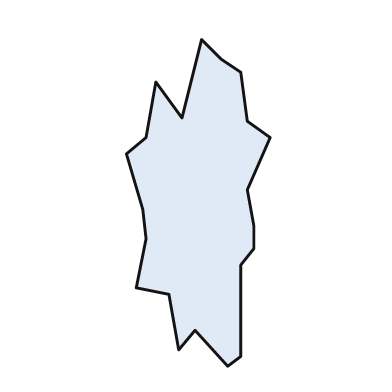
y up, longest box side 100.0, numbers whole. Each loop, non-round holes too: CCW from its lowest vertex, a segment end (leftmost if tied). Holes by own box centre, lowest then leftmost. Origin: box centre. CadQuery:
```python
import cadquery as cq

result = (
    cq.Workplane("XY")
    .moveTo(9.0, -50.0)
    .lineTo(13.0, -47.0)
    .lineTo(13.0, -19.0)
    .lineTo(17.0, -14.0)
    .lineTo(17.0, -7.0)
    .lineTo(15.0, 4.0)
    .lineTo(22.0, 20.0)
    .lineTo(15.0, 25.0)
    .lineTo(13.0, 40.0)
    .lineTo(7.0, 44.0)
    .lineTo(1.0, 50.0)
    .lineTo(-5.0, 26.0)
    .lineTo(-13.0, 37.0)
    .lineTo(-16.0, 20.0)
    .lineTo(-22.0, 15.0)
    .lineTo(-17.0, -2.0)
    .lineTo(-16.0, -11.0)
    .lineTo(-19.0, -26.0)
    .lineTo(-9.0, -28.0)
    .lineTo(-6.0, -45.0)
    .lineTo(-1.0, -39.0)
    .close()
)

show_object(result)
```